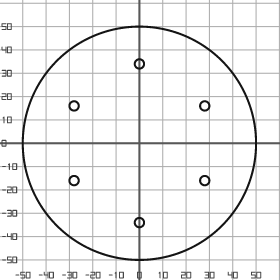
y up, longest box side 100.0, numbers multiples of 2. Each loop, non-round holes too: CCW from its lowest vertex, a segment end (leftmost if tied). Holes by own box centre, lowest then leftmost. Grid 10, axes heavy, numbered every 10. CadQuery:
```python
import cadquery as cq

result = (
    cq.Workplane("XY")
    .moveTo(0.0, 0.0)
    .circle(50.0)
    .moveTo(0.0, -34.0)
    .circle(2.0)
    .moveTo(-28.0, -16.0)
    .circle(2.0)
    .moveTo(28.0, -16.0)
    .circle(2.0)
    .moveTo(-28.0, 16.0)
    .circle(2.0)
    .moveTo(28.0, 16.0)
    .circle(2.0)
    .moveTo(0.0, 34.0)
    .circle(2.0)
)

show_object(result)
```